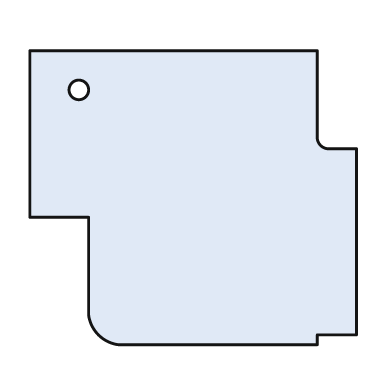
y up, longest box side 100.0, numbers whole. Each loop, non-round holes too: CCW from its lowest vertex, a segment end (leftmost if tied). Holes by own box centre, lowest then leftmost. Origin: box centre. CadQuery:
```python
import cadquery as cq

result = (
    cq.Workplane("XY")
    .moveTo(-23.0, -45.0)
    .lineTo(38.0, -45.0)
    .lineTo(38.0, -42.0)
    .lineTo(50.0, -42.0)
    .lineTo(50.0, 15.0)
    .lineTo(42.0, 15.0)
    .threePointArc((39.0, 16.0), (38.0, 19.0))
    .lineTo(38.0, 45.0)
    .lineTo(-50.0, 45.0)
    .lineTo(-50.0, -6.0)
    .lineTo(-32.0, -6.0)
    .lineTo(-32.0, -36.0)
    .threePointArc((-29.0, -42.0), (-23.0, -45.0))
    .close()
    .moveTo(-35.0, 33.0)
    .circle(3.0)
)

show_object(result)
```